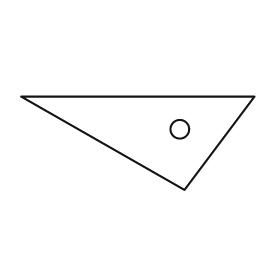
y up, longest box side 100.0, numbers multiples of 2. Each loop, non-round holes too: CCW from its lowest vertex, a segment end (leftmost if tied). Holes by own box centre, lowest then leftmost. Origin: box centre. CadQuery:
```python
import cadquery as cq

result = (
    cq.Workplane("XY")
    .moveTo(20.0, -20.0)
    .lineTo(50.0, 20.0)
    .lineTo(-50.0, 20.0)
    .close()
    .moveTo(18.0, 6.0)
    .circle(4.0)
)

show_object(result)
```